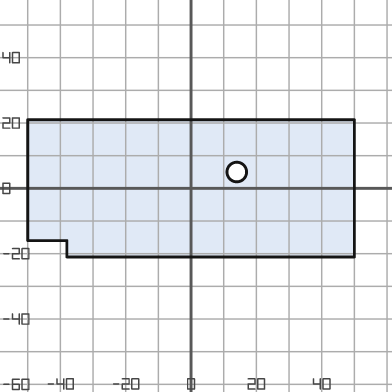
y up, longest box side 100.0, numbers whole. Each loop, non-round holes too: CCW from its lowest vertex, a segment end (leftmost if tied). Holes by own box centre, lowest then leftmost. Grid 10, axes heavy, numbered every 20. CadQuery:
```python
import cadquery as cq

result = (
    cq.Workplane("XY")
    .moveTo(-38.0, -21.0)
    .lineTo(50.0, -21.0)
    .lineTo(50.0, 21.0)
    .lineTo(-50.0, 21.0)
    .lineTo(-50.0, -16.0)
    .lineTo(-38.0, -16.0)
    .close()
    .moveTo(14.0, 5.0)
    .circle(3.0)
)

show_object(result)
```